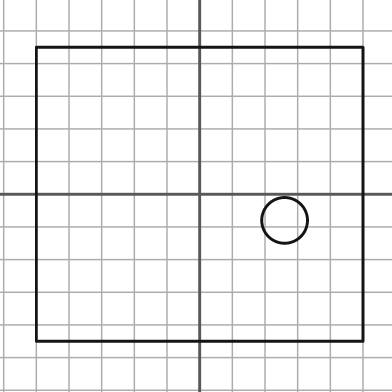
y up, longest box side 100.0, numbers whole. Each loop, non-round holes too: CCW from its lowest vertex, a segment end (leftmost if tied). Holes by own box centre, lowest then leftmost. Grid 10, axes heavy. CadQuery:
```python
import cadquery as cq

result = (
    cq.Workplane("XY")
    .moveTo(-50.0, -45.0)
    .lineTo(50.0, -45.0)
    .lineTo(50.0, 45.0)
    .lineTo(-50.0, 45.0)
    .close()
    .moveTo(26.0, -8.0)
    .circle(7.0)
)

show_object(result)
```